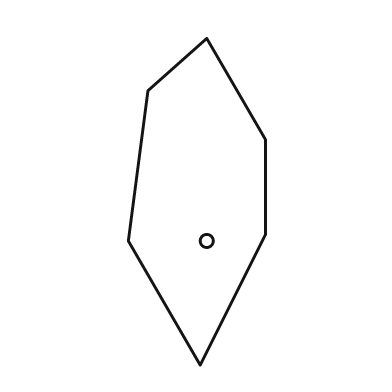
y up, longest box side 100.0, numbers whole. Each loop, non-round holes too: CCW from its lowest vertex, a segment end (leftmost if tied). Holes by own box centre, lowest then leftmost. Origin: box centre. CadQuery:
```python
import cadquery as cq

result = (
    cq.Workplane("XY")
    .moveTo(1.0, -50.0)
    .lineTo(21.0, -10.0)
    .lineTo(21.0, 19.0)
    .lineTo(3.0, 50.0)
    .lineTo(-15.0, 34.0)
    .lineTo(-21.0, -12.0)
    .close()
    .moveTo(3.0, -12.0)
    .circle(2.0)
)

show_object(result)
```